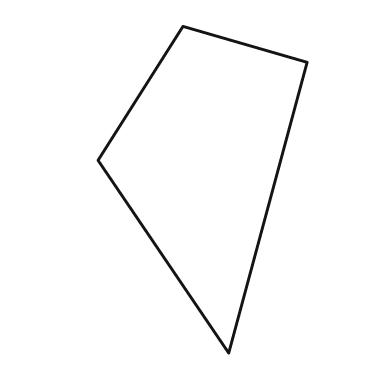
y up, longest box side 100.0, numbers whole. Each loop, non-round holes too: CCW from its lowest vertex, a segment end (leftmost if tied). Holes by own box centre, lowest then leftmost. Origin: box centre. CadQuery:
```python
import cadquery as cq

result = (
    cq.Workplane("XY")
    .moveTo(8.0, -50.0)
    .lineTo(32.0, 39.0)
    .lineTo(-6.0, 50.0)
    .lineTo(-32.0, 9.0)
    .close()
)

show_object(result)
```